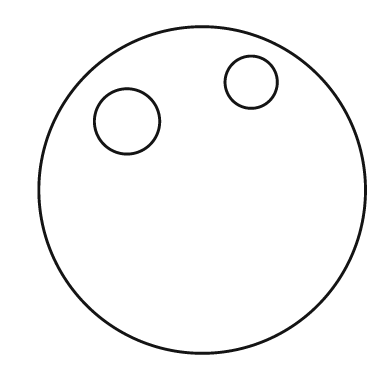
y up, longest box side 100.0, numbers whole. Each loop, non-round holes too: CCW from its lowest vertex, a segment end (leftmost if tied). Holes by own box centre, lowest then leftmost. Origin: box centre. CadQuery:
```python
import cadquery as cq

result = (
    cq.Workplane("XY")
    .moveTo(0.0, 0.0)
    .circle(50.0)
    .moveTo(-23.0, 21.0)
    .circle(10.0)
    .moveTo(15.0, 33.0)
    .circle(8.0)
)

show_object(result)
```